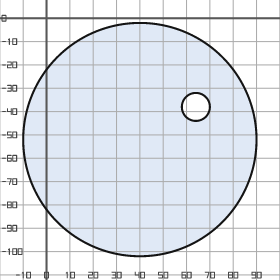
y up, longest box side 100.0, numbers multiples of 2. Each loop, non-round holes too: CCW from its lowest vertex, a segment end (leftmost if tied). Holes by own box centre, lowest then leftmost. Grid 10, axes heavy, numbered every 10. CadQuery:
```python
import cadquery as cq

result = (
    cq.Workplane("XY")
    .moveTo(40.0, -52.0)
    .circle(50.0)
    .moveTo(64.0, -38.0)
    .circle(6.0)
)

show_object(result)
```